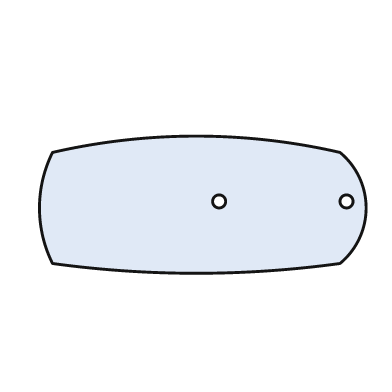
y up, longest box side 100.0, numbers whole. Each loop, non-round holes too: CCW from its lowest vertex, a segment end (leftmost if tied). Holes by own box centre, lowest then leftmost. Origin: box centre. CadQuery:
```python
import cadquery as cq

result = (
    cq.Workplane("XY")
    .moveTo(-46.0, -18.0)
    .threePointArc((-2.0, -21.0), (42.0, -18.0))
    .threePointArc((50.0, -1.0), (42.0, 16.0))
    .threePointArc((-2.0, 21.0), (-46.0, 16.0))
    .threePointArc((-50.0, -1.0), (-46.0, -18.0))
    .close()
    .moveTo(5.0, 1.0)
    .circle(2.0)
    .moveTo(44.0, 1.0)
    .circle(2.0)
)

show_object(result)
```